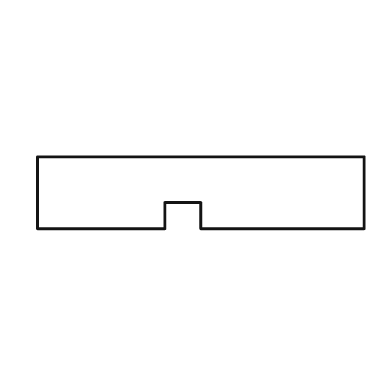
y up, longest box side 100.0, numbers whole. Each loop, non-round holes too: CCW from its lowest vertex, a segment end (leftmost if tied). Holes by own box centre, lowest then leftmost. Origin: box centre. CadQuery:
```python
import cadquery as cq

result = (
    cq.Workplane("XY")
    .moveTo(-50.0, -11.0)
    .lineTo(-11.0, -11.0)
    .lineTo(-11.0, -3.0)
    .lineTo(0.0, -3.0)
    .lineTo(0.0, -11.0)
    .lineTo(50.0, -11.0)
    .lineTo(50.0, 11.0)
    .lineTo(-50.0, 11.0)
    .close()
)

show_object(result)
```